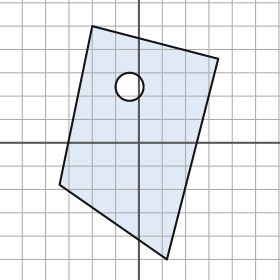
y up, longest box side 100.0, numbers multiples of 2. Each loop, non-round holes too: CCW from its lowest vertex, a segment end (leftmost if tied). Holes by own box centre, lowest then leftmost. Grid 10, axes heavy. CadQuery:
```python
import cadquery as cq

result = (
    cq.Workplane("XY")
    .moveTo(12.0, -50.0)
    .lineTo(34.0, 36.0)
    .lineTo(-20.0, 50.0)
    .lineTo(-34.0, -18.0)
    .close()
    .moveTo(-4.0, 24.0)
    .circle(6.0)
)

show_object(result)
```